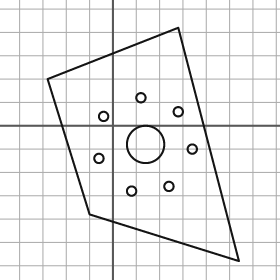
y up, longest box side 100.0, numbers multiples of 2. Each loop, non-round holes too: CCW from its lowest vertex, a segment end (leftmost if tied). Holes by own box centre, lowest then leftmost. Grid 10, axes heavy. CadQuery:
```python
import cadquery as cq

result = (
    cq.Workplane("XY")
    .moveTo(54.0, -58.0)
    .lineTo(28.0, 42.0)
    .lineTo(-28.0, 20.0)
    .lineTo(-10.0, -38.0)
    .close()
    .moveTo(8.0, -28.0)
    .circle(2.0)
    .moveTo(24.0, -26.0)
    .circle(2.0)
    .moveTo(-6.0, -14.0)
    .circle(2.0)
    .moveTo(34.0, -10.0)
    .circle(2.0)
    .moveTo(14.0, -8.0)
    .circle(8.0)
    .moveTo(-4.0, 4.0)
    .circle(2.0)
    .moveTo(28.0, 6.0)
    .circle(2.0)
    .moveTo(12.0, 12.0)
    .circle(2.0)
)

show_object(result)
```